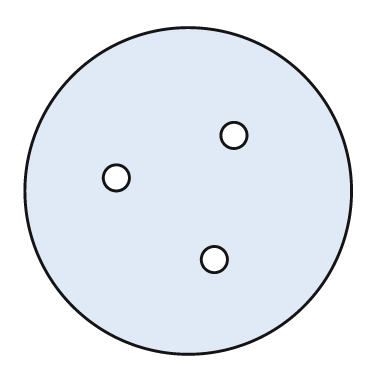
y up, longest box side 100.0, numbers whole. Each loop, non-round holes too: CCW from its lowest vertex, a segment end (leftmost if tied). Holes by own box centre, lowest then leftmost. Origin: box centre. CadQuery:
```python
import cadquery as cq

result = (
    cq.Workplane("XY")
    .moveTo(0.0, 0.0)
    .circle(50.0)
    .moveTo(8.0, -21.0)
    .circle(4.0)
    .moveTo(-22.0, 4.0)
    .circle(4.0)
    .moveTo(14.0, 17.0)
    .circle(4.0)
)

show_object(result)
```